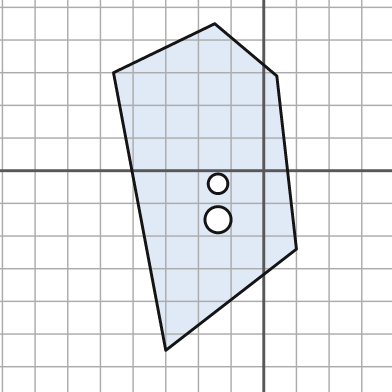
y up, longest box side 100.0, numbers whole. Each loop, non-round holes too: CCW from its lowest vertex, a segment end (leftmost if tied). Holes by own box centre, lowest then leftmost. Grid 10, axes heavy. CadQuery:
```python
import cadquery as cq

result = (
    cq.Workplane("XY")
    .moveTo(-30.0, -55.0)
    .lineTo(10.0, -24.0)
    .lineTo(4.0, 29.0)
    .lineTo(-15.0, 45.0)
    .lineTo(-46.0, 30.0)
    .close()
    .moveTo(-14.0, -15.0)
    .circle(4.0)
    .moveTo(-14.0, -4.0)
    .circle(3.0)
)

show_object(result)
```